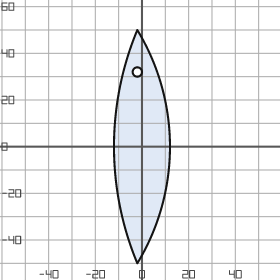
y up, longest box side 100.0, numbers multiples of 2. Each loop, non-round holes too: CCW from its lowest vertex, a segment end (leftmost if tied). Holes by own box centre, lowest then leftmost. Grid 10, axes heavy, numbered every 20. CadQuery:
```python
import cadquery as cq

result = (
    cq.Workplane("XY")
    .moveTo(-2.0, -50.0)
    .threePointArc((12.0, 0.0), (-2.0, 50.0))
    .threePointArc((-12.0, 0.0), (-2.0, -50.0))
    .close()
    .moveTo(-2.0, 32.0)
    .circle(2.0)
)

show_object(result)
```